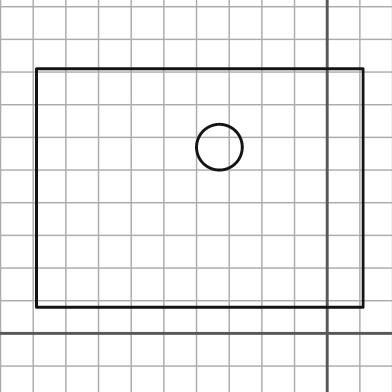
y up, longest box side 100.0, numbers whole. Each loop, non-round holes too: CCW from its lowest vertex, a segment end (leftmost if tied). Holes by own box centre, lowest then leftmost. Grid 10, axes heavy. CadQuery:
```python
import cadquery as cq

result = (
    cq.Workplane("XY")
    .moveTo(-89.0, 8.0)
    .lineTo(11.0, 8.0)
    .lineTo(11.0, 81.0)
    .lineTo(-89.0, 81.0)
    .close()
    .moveTo(-33.0, 57.0)
    .circle(7.0)
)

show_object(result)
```